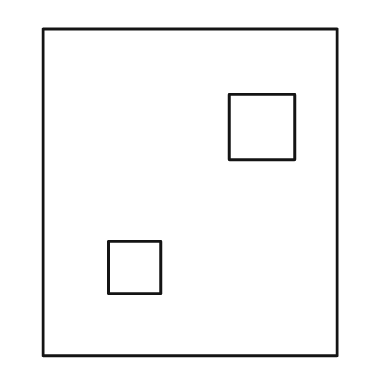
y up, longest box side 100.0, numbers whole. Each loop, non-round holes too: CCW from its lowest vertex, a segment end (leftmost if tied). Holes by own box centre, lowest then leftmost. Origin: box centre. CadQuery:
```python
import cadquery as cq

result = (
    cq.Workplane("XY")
    .moveTo(-45.0, -50.0)
    .lineTo(45.0, -50.0)
    .lineTo(45.0, 50.0)
    .lineTo(-45.0, 50.0)
    .close()
    .moveTo(-25.0, -31.0)
    .lineTo(-9.0, -31.0)
    .lineTo(-9.0, -15.0)
    .lineTo(-25.0, -15.0)
    .close()
    .moveTo(12.0, 10.0)
    .lineTo(32.0, 10.0)
    .lineTo(32.0, 30.0)
    .lineTo(12.0, 30.0)
    .close()
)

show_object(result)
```